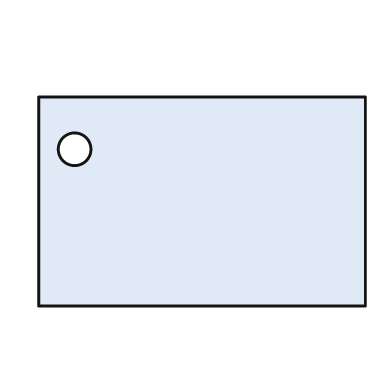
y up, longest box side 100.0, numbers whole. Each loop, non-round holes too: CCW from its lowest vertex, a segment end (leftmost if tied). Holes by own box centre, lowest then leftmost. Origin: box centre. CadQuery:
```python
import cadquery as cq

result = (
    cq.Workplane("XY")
    .moveTo(-50.0, -32.0)
    .lineTo(50.0, -32.0)
    .lineTo(50.0, 32.0)
    .lineTo(-50.0, 32.0)
    .close()
    .moveTo(-39.0, 16.0)
    .circle(5.0)
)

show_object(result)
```